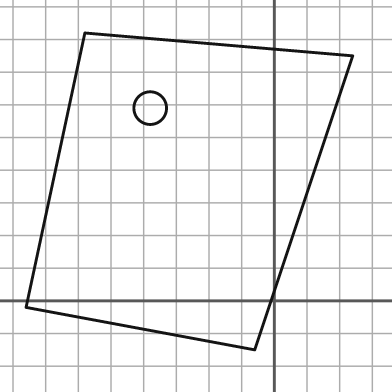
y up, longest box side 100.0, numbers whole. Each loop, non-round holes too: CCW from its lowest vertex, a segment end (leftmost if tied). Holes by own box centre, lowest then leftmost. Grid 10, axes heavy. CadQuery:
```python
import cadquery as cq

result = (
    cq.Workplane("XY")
    .moveTo(-6.0, -15.0)
    .lineTo(24.0, 75.0)
    .lineTo(-58.0, 82.0)
    .lineTo(-76.0, -2.0)
    .close()
    .moveTo(-38.0, 59.0)
    .circle(5.0)
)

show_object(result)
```